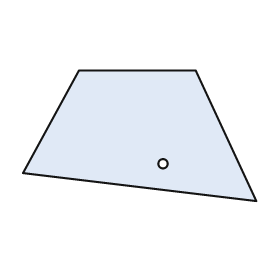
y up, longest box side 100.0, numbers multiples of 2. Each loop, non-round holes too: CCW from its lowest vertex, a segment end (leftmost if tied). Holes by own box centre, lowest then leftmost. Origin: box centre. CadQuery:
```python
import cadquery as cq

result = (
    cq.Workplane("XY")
    .moveTo(50.0, -28.0)
    .lineTo(24.0, 28.0)
    .lineTo(-26.0, 28.0)
    .lineTo(-50.0, -16.0)
    .close()
    .moveTo(10.0, -12.0)
    .circle(2.0)
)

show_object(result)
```